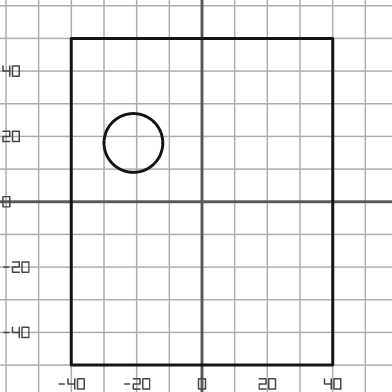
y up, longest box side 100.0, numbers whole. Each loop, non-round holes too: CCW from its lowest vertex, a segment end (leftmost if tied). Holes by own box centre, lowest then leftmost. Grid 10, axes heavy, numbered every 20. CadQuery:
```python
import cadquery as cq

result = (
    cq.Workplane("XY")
    .moveTo(-40.0, -50.0)
    .lineTo(40.0, -50.0)
    .lineTo(40.0, 50.0)
    .lineTo(-40.0, 50.0)
    .close()
    .moveTo(-21.0, 18.0)
    .circle(9.0)
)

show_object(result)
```